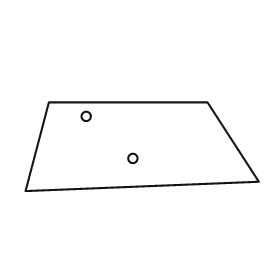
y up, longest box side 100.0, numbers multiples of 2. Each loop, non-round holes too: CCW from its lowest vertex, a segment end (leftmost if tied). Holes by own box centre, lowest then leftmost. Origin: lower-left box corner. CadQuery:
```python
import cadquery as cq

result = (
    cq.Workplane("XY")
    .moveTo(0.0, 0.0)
    .lineTo(100.0, 4.0)
    .lineTo(78.0, 38.0)
    .lineTo(10.0, 38.0)
    .close()
    .moveTo(46.0, 14.0)
    .circle(2.0)
    .moveTo(26.0, 32.0)
    .circle(2.0)
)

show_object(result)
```